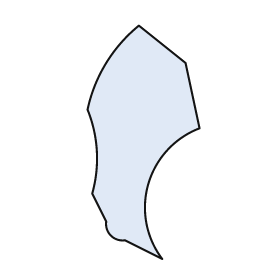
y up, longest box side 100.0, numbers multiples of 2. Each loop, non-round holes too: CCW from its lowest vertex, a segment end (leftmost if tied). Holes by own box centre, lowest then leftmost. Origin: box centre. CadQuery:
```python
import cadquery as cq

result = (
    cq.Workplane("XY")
    .moveTo(8.0, -50.0)
    .threePointArc((2.0, -18.0), (24.0, 6.0))
    .lineTo(18.0, 34.0)
    .lineTo(-2.0, 50.0)
    .threePointArc((-16.0, 34.0), (-24.0, 14.0))
    .threePointArc((-20.0, -4.0), (-22.0, -22.0))
    .lineTo(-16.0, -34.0)
    .threePointArc((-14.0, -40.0), (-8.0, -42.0))
    .close()
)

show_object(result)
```